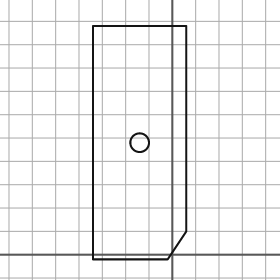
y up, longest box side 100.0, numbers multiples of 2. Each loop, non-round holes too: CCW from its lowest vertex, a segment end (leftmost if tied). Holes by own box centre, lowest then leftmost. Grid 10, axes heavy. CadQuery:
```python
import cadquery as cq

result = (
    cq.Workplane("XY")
    .moveTo(-34.0, -2.0)
    .lineTo(-2.0, -2.0)
    .lineTo(6.0, 10.0)
    .lineTo(6.0, 98.0)
    .lineTo(-34.0, 98.0)
    .close()
    .moveTo(-14.0, 48.0)
    .circle(4.0)
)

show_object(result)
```